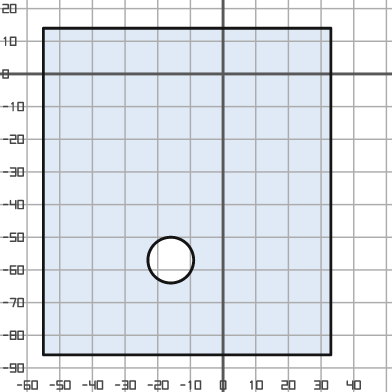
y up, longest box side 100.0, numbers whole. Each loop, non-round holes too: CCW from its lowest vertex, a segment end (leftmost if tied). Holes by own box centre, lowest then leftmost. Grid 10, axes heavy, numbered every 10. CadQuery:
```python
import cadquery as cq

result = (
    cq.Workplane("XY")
    .moveTo(-55.0, -86.0)
    .lineTo(33.0, -86.0)
    .lineTo(33.0, 14.0)
    .lineTo(-55.0, 14.0)
    .close()
    .moveTo(-16.0, -57.0)
    .circle(7.0)
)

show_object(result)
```